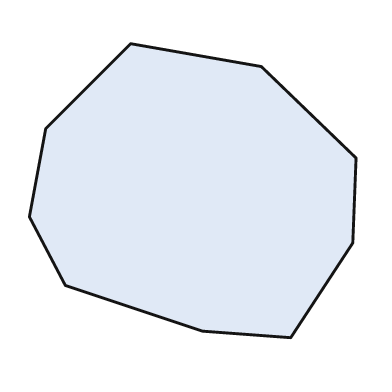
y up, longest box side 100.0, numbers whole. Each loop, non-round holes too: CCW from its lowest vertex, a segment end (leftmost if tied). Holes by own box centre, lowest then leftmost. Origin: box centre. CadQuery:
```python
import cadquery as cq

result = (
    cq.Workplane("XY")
    .moveTo(30.0, -45.0)
    .lineTo(49.0, -16.0)
    .lineTo(50.0, 10.0)
    .lineTo(21.0, 38.0)
    .lineTo(-19.0, 45.0)
    .lineTo(-45.0, 19.0)
    .lineTo(-50.0, -8.0)
    .lineTo(-39.0, -29.0)
    .lineTo(3.0, -43.0)
    .close()
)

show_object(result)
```